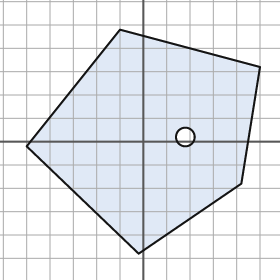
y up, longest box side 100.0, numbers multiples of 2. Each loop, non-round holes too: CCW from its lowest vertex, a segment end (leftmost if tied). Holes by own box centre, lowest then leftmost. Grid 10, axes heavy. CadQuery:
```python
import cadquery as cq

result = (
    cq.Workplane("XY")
    .moveTo(-2.0, -48.0)
    .lineTo(42.0, -18.0)
    .lineTo(50.0, 32.0)
    .lineTo(-10.0, 48.0)
    .lineTo(-50.0, -2.0)
    .close()
    .moveTo(18.0, 2.0)
    .circle(4.0)
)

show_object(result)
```